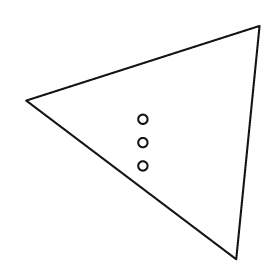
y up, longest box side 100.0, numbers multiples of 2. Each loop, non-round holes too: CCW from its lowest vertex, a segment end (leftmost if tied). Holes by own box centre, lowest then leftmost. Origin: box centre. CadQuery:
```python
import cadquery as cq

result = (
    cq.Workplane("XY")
    .moveTo(40.0, -50.0)
    .lineTo(50.0, 50.0)
    .lineTo(-50.0, 18.0)
    .close()
    .moveTo(0.0, -10.0)
    .circle(2.0)
    .moveTo(0.0, 0.0)
    .circle(2.0)
    .moveTo(0.0, 10.0)
    .circle(2.0)
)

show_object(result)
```